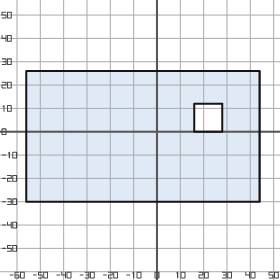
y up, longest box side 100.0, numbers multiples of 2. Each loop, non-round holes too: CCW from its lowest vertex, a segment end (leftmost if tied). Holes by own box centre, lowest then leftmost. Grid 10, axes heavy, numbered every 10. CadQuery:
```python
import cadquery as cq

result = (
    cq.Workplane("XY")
    .moveTo(-56.0, -30.0)
    .lineTo(44.0, -30.0)
    .lineTo(44.0, 26.0)
    .lineTo(-56.0, 26.0)
    .close()
    .moveTo(16.0, 0.0)
    .lineTo(28.0, 0.0)
    .lineTo(28.0, 12.0)
    .lineTo(16.0, 12.0)
    .close()
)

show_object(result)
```